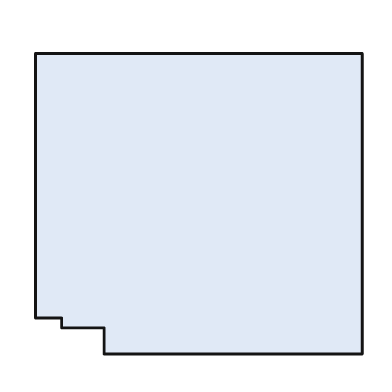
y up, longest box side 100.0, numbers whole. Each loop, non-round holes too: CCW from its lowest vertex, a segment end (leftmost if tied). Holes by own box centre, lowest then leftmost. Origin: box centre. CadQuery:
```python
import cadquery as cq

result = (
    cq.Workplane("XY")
    .moveTo(-29.0, -46.0)
    .lineTo(50.0, -46.0)
    .lineTo(50.0, 46.0)
    .lineTo(-50.0, 46.0)
    .lineTo(-50.0, -35.0)
    .lineTo(-42.0, -35.0)
    .lineTo(-42.0, -38.0)
    .lineTo(-29.0, -38.0)
    .close()
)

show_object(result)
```